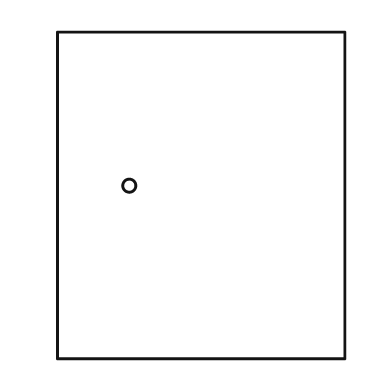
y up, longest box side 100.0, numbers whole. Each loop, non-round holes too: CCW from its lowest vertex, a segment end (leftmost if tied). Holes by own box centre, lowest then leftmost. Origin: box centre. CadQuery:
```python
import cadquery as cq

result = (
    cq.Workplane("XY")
    .moveTo(-44.0, -50.0)
    .lineTo(44.0, -50.0)
    .lineTo(44.0, 50.0)
    .lineTo(-44.0, 50.0)
    .close()
    .moveTo(-22.0, 3.0)
    .circle(2.0)
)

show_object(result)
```